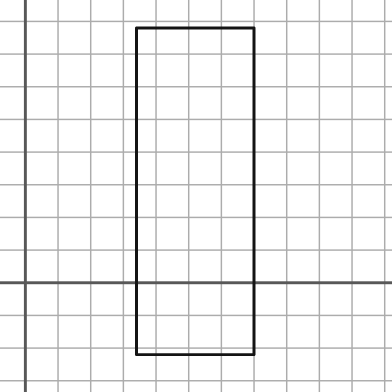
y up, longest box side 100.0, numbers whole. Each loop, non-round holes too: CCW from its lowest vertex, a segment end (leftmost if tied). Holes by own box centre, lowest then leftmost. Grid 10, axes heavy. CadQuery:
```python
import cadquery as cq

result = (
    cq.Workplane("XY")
    .moveTo(34.0, -22.0)
    .lineTo(70.0, -22.0)
    .lineTo(70.0, 78.0)
    .lineTo(34.0, 78.0)
    .close()
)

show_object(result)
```